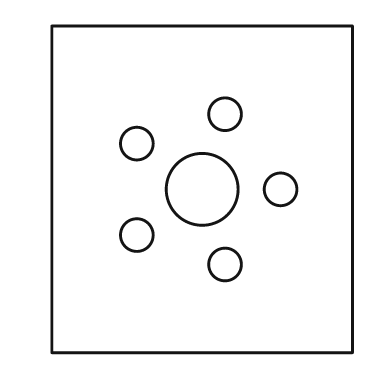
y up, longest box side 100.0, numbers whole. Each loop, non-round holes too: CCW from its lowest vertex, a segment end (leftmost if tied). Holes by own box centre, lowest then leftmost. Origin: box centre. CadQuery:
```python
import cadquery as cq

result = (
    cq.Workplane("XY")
    .moveTo(-46.0, -50.0)
    .lineTo(46.0, -50.0)
    .lineTo(46.0, 50.0)
    .lineTo(-46.0, 50.0)
    .close()
    .moveTo(7.0, -23.0)
    .circle(5.0)
    .moveTo(-20.0, -14.0)
    .circle(5.0)
    .moveTo(0.0, 0.0)
    .circle(11.0)
    .moveTo(24.0, 0.0)
    .circle(5.0)
    .moveTo(-20.0, 14.0)
    .circle(5.0)
    .moveTo(7.0, 23.0)
    .circle(5.0)
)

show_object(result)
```